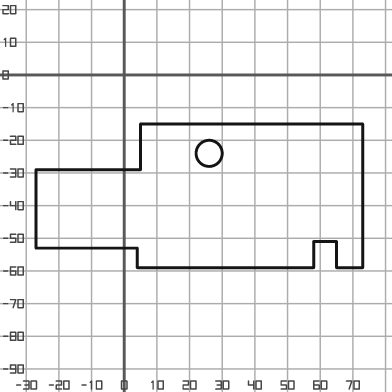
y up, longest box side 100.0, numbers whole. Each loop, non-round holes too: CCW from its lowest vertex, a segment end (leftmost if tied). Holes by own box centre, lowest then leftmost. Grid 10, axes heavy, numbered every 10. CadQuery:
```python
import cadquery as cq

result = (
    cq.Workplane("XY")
    .moveTo(4.0, -59.0)
    .lineTo(58.0, -59.0)
    .lineTo(58.0, -51.0)
    .lineTo(65.0, -51.0)
    .lineTo(65.0, -59.0)
    .lineTo(73.0, -59.0)
    .lineTo(73.0, -15.0)
    .lineTo(5.0, -15.0)
    .lineTo(5.0, -29.0)
    .lineTo(-27.0, -29.0)
    .lineTo(-27.0, -53.0)
    .lineTo(4.0, -53.0)
    .close()
    .moveTo(26.0, -24.0)
    .circle(4.0)
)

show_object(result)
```